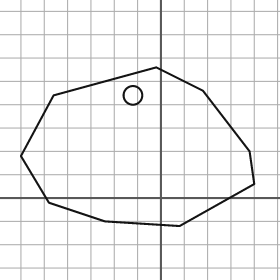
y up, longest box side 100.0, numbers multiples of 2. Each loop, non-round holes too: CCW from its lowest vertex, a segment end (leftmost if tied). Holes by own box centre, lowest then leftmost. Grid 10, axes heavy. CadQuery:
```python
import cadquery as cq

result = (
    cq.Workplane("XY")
    .moveTo(8.0, -12.0)
    .lineTo(40.0, 6.0)
    .lineTo(38.0, 20.0)
    .lineTo(18.0, 46.0)
    .lineTo(-2.0, 56.0)
    .lineTo(-46.0, 44.0)
    .lineTo(-60.0, 18.0)
    .lineTo(-48.0, -2.0)
    .lineTo(-24.0, -10.0)
    .close()
    .moveTo(-12.0, 44.0)
    .circle(4.0)
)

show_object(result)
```